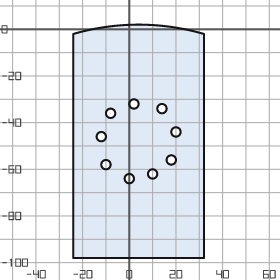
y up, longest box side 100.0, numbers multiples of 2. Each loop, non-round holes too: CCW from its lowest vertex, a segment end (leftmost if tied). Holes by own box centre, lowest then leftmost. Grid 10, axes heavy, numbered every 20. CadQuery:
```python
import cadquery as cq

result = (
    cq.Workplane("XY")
    .moveTo(-24.0, -98.0)
    .lineTo(32.0, -98.0)
    .lineTo(32.0, -2.0)
    .threePointArc((4.0, 2.0), (-24.0, -2.0))
    .close()
    .moveTo(0.0, -64.0)
    .circle(2.0)
    .moveTo(10.0, -62.0)
    .circle(2.0)
    .moveTo(-10.0, -58.0)
    .circle(2.0)
    .moveTo(18.0, -56.0)
    .circle(2.0)
    .moveTo(-12.0, -46.0)
    .circle(2.0)
    .moveTo(20.0, -44.0)
    .circle(2.0)
    .moveTo(-8.0, -36.0)
    .circle(2.0)
    .moveTo(14.0, -34.0)
    .circle(2.0)
    .moveTo(2.0, -32.0)
    .circle(2.0)
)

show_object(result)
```